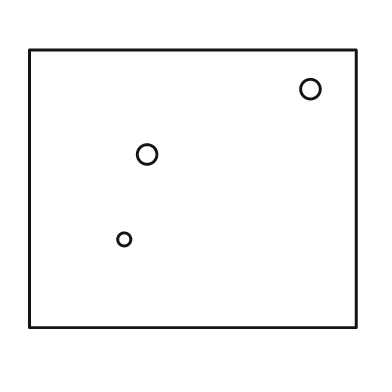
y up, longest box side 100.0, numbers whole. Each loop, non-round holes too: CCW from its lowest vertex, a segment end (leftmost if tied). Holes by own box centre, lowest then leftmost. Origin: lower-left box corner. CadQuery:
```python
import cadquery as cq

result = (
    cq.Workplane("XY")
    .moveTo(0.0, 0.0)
    .lineTo(100.0, 0.0)
    .lineTo(100.0, 85.0)
    .lineTo(0.0, 85.0)
    .close()
    .moveTo(29.0, 27.0)
    .circle(2.0)
    .moveTo(36.0, 53.0)
    .circle(3.0)
    .moveTo(86.0, 73.0)
    .circle(3.0)
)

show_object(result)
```